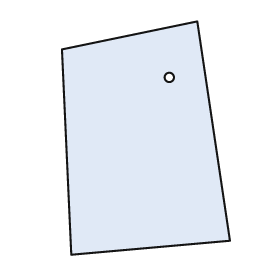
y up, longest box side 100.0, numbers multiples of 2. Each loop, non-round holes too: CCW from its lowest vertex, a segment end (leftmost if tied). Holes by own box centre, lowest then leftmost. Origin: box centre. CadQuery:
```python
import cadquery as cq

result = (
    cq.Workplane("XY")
    .moveTo(-32.0, -50.0)
    .lineTo(36.0, -44.0)
    .lineTo(22.0, 50.0)
    .lineTo(-36.0, 38.0)
    .close()
    .moveTo(10.0, 26.0)
    .circle(2.0)
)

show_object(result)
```